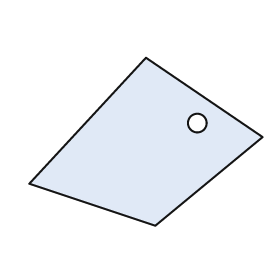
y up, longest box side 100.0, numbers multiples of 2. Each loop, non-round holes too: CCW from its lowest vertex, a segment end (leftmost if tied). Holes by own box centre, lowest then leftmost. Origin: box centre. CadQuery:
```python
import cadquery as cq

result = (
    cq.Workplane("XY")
    .moveTo(4.0, -36.0)
    .lineTo(50.0, 2.0)
    .lineTo(0.0, 36.0)
    .lineTo(-50.0, -18.0)
    .close()
    .moveTo(22.0, 8.0)
    .circle(4.0)
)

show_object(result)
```